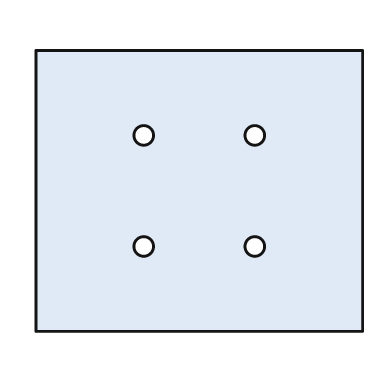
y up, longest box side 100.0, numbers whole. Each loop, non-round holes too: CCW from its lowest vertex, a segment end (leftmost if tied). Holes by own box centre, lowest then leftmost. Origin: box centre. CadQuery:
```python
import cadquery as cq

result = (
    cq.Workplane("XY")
    .moveTo(-50.0, -43.0)
    .lineTo(50.0, -43.0)
    .lineTo(50.0, 43.0)
    .lineTo(-50.0, 43.0)
    .close()
    .moveTo(-17.0, -17.0)
    .circle(3.0)
    .moveTo(17.0, -17.0)
    .circle(3.0)
    .moveTo(-17.0, 17.0)
    .circle(3.0)
    .moveTo(17.0, 17.0)
    .circle(3.0)
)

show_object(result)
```